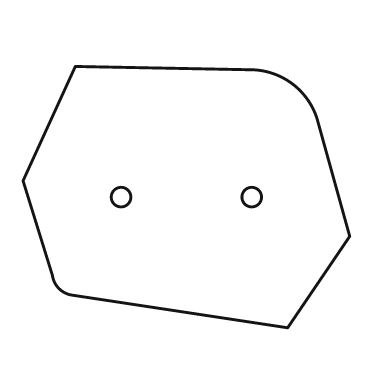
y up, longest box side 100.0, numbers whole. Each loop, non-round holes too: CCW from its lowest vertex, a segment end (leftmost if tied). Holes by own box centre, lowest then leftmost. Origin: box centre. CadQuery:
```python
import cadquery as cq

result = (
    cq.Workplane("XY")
    .moveTo(31.0, -40.0)
    .lineTo(50.0, -12.0)
    .lineTo(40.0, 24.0)
    .threePointArc((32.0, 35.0), (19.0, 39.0))
    .lineTo(-34.0, 40.0)
    .lineTo(-50.0, 5.0)
    .lineTo(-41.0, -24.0)
    .threePointArc((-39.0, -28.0), (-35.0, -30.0))
    .close()
    .moveTo(-20.0, 0.0)
    .circle(3.0)
    .moveTo(20.0, 0.0)
    .circle(3.0)
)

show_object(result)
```